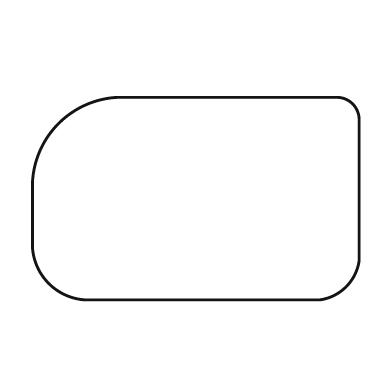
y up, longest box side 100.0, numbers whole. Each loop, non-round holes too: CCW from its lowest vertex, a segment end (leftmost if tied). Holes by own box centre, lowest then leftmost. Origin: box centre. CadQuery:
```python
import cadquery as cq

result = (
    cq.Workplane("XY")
    .moveTo(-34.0, -31.0)
    .lineTo(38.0, -31.0)
    .threePointArc((46.0, -27.0), (50.0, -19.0))
    .lineTo(50.0, 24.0)
    .threePointArc((48.0, 29.0), (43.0, 31.0))
    .lineTo(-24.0, 31.0)
    .threePointArc((-42.0, 23.0), (-50.0, 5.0))
    .lineTo(-50.0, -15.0)
    .threePointArc((-45.0, -26.0), (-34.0, -31.0))
    .close()
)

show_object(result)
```